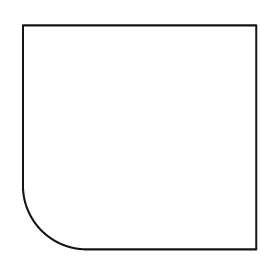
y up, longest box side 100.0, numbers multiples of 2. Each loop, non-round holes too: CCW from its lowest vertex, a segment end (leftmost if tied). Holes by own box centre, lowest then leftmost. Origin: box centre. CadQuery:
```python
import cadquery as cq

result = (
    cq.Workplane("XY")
    .moveTo(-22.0, -48.0)
    .lineTo(50.0, -48.0)
    .lineTo(50.0, 48.0)
    .lineTo(-50.0, 48.0)
    .lineTo(-50.0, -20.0)
    .threePointArc((-42.0, -40.0), (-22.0, -48.0))
    .close()
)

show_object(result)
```